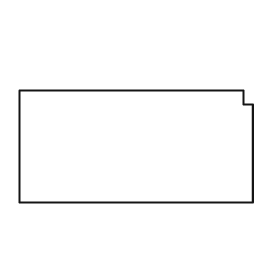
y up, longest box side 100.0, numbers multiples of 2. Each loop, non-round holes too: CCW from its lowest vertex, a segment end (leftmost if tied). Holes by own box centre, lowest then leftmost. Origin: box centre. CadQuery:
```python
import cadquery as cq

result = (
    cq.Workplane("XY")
    .moveTo(-50.0, -24.0)
    .lineTo(50.0, -24.0)
    .lineTo(50.0, 18.0)
    .lineTo(46.0, 18.0)
    .lineTo(46.0, 24.0)
    .lineTo(-50.0, 24.0)
    .close()
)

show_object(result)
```